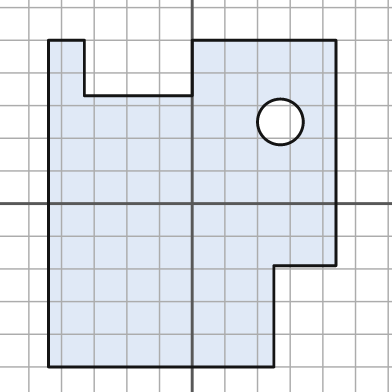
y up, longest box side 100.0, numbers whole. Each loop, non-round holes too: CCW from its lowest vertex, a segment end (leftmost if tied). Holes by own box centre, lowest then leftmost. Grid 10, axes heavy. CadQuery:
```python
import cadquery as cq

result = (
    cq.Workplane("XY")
    .moveTo(-44.0, -50.0)
    .lineTo(25.0, -50.0)
    .lineTo(25.0, -19.0)
    .lineTo(44.0, -19.0)
    .lineTo(44.0, 50.0)
    .lineTo(0.0, 50.0)
    .lineTo(0.0, 33.0)
    .lineTo(-33.0, 33.0)
    .lineTo(-33.0, 50.0)
    .lineTo(-44.0, 50.0)
    .close()
    .moveTo(27.0, 25.0)
    .circle(7.0)
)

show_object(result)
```